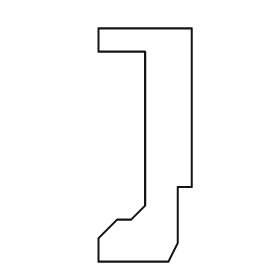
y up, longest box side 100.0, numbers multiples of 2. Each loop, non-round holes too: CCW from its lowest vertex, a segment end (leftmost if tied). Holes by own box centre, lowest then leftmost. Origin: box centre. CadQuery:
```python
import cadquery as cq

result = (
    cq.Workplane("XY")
    .moveTo(-20.0, -50.0)
    .lineTo(10.0, -50.0)
    .lineTo(14.0, -42.0)
    .lineTo(14.0, -18.0)
    .lineTo(20.0, -18.0)
    .lineTo(20.0, 50.0)
    .lineTo(-20.0, 50.0)
    .lineTo(-20.0, 40.0)
    .lineTo(0.0, 40.0)
    .lineTo(0.0, -26.0)
    .lineTo(-6.0, -32.0)
    .lineTo(-12.0, -32.0)
    .lineTo(-20.0, -40.0)
    .close()
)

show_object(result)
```